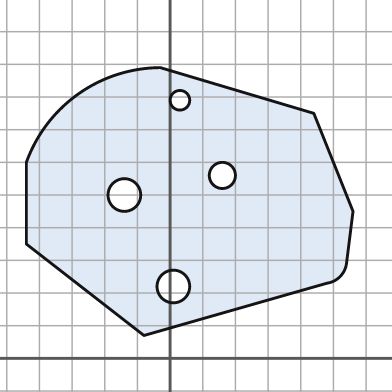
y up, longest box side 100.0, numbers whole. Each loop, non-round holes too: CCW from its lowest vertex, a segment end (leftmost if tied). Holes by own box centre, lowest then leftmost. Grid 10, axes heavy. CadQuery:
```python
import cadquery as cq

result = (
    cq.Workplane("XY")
    .moveTo(-8.0, 7.0)
    .lineTo(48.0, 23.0)
    .threePointArc((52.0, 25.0), (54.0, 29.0))
    .lineTo(56.0, 45.0)
    .lineTo(44.0, 75.0)
    .lineTo(-3.0, 89.0)
    .threePointArc((-28.0, 81.0), (-44.0, 60.0))
    .lineTo(-44.0, 35.0)
    .close()
    .moveTo(1.0, 22.0)
    .circle(5.0)
    .moveTo(-14.0, 50.0)
    .circle(5.0)
    .moveTo(16.0, 56.0)
    .circle(4.0)
    .moveTo(3.0, 79.0)
    .circle(3.0)
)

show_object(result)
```